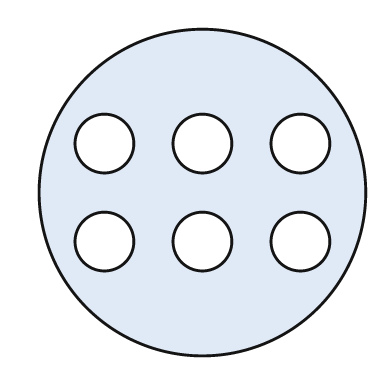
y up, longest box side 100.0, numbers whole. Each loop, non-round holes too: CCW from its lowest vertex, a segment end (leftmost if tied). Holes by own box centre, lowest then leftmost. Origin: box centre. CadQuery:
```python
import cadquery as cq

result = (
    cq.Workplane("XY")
    .moveTo(0.0, 0.0)
    .circle(50.0)
    .moveTo(-30.0, -15.0)
    .circle(9.0)
    .moveTo(0.0, -15.0)
    .circle(9.0)
    .moveTo(30.0, -15.0)
    .circle(9.0)
    .moveTo(-30.0, 15.0)
    .circle(9.0)
    .moveTo(0.0, 15.0)
    .circle(9.0)
    .moveTo(30.0, 15.0)
    .circle(9.0)
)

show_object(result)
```